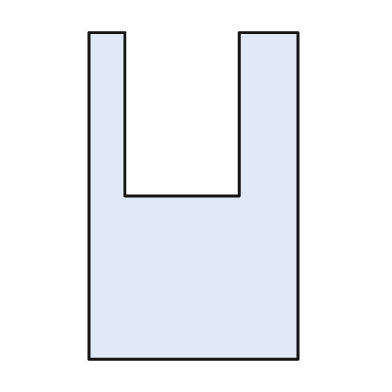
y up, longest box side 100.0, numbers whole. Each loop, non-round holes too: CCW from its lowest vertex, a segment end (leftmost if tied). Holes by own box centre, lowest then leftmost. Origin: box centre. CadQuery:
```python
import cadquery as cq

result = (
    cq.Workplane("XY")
    .moveTo(-32.0, -50.0)
    .lineTo(32.0, -50.0)
    .lineTo(32.0, 50.0)
    .lineTo(14.0, 50.0)
    .lineTo(14.0, 0.0)
    .lineTo(-21.0, 0.0)
    .lineTo(-21.0, 50.0)
    .lineTo(-32.0, 50.0)
    .close()
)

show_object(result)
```